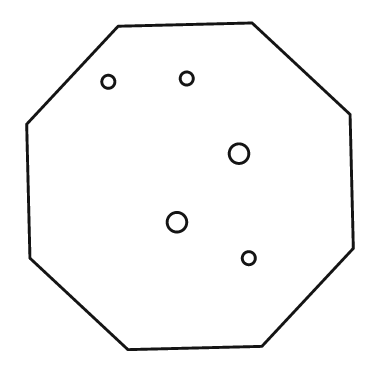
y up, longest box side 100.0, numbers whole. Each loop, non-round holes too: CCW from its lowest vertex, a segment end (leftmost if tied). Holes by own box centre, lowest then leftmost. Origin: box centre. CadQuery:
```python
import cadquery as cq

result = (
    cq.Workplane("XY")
    .moveTo(-19.0, -50.0)
    .lineTo(22.0, -49.0)
    .lineTo(50.0, -19.0)
    .lineTo(49.0, 22.0)
    .lineTo(19.0, 50.0)
    .lineTo(-22.0, 49.0)
    .lineTo(-50.0, 19.0)
    .lineTo(-49.0, -22.0)
    .close()
    .moveTo(18.0, -22.0)
    .circle(2.0)
    .moveTo(-4.0, -11.0)
    .circle(3.0)
    .moveTo(15.0, 10.0)
    .circle(3.0)
    .moveTo(-25.0, 32.0)
    .circle(2.0)
    .moveTo(-1.0, 33.0)
    .circle(2.0)
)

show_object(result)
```